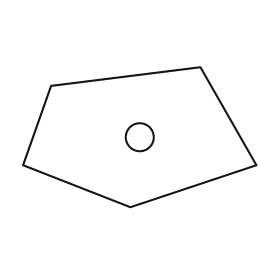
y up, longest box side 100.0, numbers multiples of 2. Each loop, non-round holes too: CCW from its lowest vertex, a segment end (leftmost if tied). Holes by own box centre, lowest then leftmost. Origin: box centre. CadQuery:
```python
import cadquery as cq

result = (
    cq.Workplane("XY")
    .moveTo(-4.0, -30.0)
    .lineTo(50.0, -12.0)
    .lineTo(26.0, 30.0)
    .lineTo(-38.0, 22.0)
    .lineTo(-50.0, -12.0)
    .close()
    .moveTo(0.0, 0.0)
    .circle(6.0)
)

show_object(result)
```